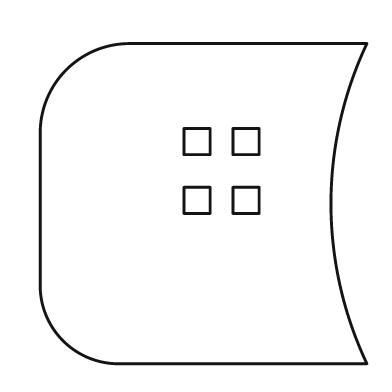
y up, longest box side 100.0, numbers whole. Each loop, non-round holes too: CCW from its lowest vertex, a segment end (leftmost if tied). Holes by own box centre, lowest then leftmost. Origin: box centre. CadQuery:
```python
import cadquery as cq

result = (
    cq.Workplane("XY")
    .moveTo(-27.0, -49.0)
    .lineTo(50.0, -49.0)
    .threePointArc((39.0, 0.0), (50.0, 49.0))
    .lineTo(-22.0, 49.0)
    .threePointArc((-42.0, 41.0), (-50.0, 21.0))
    .lineTo(-50.0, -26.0)
    .threePointArc((-43.0, -42.0), (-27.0, -49.0))
    .close()
    .moveTo(-6.0, -3.0)
    .lineTo(2.0, -3.0)
    .lineTo(2.0, 5.0)
    .lineTo(-6.0, 5.0)
    .close()
    .moveTo(9.0, -3.0)
    .lineTo(17.0, -3.0)
    .lineTo(17.0, 5.0)
    .lineTo(9.0, 5.0)
    .close()
    .moveTo(-6.0, 15.0)
    .lineTo(2.0, 15.0)
    .lineTo(2.0, 23.0)
    .lineTo(-6.0, 23.0)
    .close()
    .moveTo(9.0, 15.0)
    .lineTo(17.0, 15.0)
    .lineTo(17.0, 23.0)
    .lineTo(9.0, 23.0)
    .close()
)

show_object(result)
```